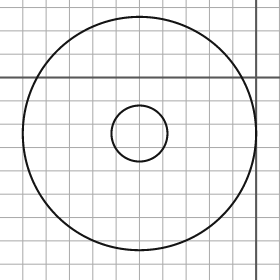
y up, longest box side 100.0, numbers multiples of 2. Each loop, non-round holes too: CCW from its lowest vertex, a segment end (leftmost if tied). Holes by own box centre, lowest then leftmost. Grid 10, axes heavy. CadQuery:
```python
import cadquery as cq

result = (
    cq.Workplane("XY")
    .moveTo(-50.0, -24.0)
    .circle(50.0)
    .moveTo(-50.0, -24.0)
    .circle(12.0)
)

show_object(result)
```